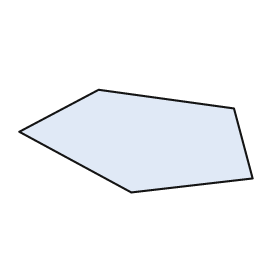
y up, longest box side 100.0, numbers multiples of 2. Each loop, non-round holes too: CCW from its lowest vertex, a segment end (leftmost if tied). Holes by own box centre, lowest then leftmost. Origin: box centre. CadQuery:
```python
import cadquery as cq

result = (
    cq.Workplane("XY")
    .moveTo(-2.0, -22.0)
    .lineTo(50.0, -16.0)
    .lineTo(42.0, 14.0)
    .lineTo(-16.0, 22.0)
    .lineTo(-50.0, 4.0)
    .close()
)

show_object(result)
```